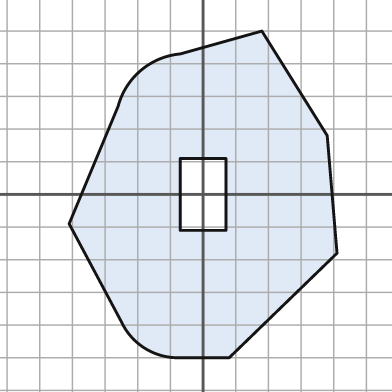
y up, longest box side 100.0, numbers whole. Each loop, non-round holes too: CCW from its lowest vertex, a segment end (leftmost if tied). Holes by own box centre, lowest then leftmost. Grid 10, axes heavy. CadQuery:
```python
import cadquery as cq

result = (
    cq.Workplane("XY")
    .moveTo(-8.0, -50.0)
    .lineTo(8.0, -50.0)
    .lineTo(41.0, -18.0)
    .lineTo(38.0, 18.0)
    .lineTo(18.0, 50.0)
    .lineTo(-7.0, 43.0)
    .threePointArc((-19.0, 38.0), (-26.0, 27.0))
    .lineTo(-41.0, -9.0)
    .lineTo(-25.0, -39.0)
    .threePointArc((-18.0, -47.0), (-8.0, -50.0))
    .close()
    .moveTo(-7.0, -11.0)
    .lineTo(7.0, -11.0)
    .lineTo(7.0, 11.0)
    .lineTo(-7.0, 11.0)
    .close()
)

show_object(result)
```